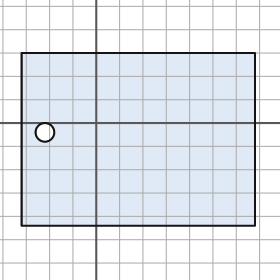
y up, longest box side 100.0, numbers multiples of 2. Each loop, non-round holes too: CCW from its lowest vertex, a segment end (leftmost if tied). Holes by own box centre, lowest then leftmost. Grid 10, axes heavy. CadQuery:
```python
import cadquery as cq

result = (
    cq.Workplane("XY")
    .moveTo(-32.0, -44.0)
    .lineTo(68.0, -44.0)
    .lineTo(68.0, 30.0)
    .lineTo(-32.0, 30.0)
    .close()
    .moveTo(-22.0, -4.0)
    .circle(4.0)
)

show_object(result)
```